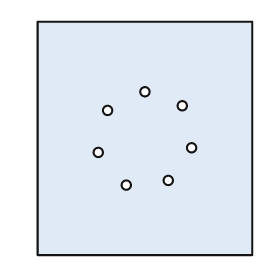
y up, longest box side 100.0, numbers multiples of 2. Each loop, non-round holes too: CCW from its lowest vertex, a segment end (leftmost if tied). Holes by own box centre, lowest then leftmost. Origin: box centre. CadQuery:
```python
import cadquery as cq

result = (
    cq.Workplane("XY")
    .moveTo(-46.0, -50.0)
    .lineTo(46.0, -50.0)
    .lineTo(46.0, 50.0)
    .lineTo(-46.0, 50.0)
    .close()
    .moveTo(-8.0, -20.0)
    .circle(2.0)
    .moveTo(10.0, -18.0)
    .circle(2.0)
    .moveTo(-20.0, -6.0)
    .circle(2.0)
    .moveTo(20.0, -4.0)
    .circle(2.0)
    .moveTo(-16.0, 12.0)
    .circle(2.0)
    .moveTo(16.0, 14.0)
    .circle(2.0)
    .moveTo(0.0, 20.0)
    .circle(2.0)
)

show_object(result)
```